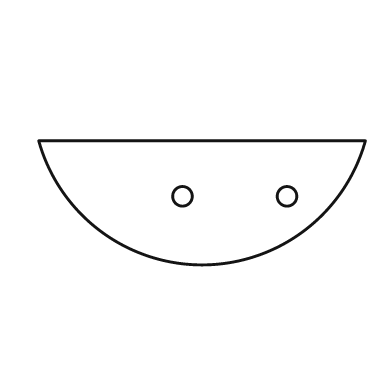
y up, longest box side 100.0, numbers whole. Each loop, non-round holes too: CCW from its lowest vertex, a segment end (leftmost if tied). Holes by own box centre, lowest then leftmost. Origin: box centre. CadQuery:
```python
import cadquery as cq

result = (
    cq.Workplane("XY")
    .moveTo(-50.0, 19.0)
    .threePointArc((0.0, -19.0), (50.0, 19.0))
    .close()
    .moveTo(-6.0, 2.0)
    .circle(3.0)
    .moveTo(26.0, 2.0)
    .circle(3.0)
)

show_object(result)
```